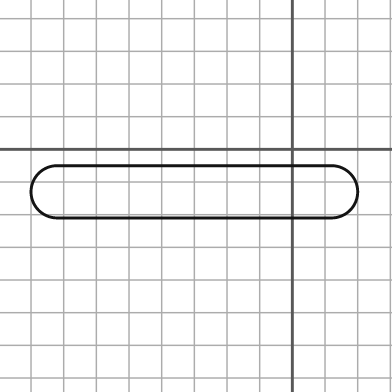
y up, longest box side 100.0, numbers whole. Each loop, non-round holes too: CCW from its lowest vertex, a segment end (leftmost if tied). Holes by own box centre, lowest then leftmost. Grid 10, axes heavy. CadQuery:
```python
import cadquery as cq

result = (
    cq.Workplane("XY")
    .moveTo(-72.0, -21.0)
    .lineTo(12.0, -21.0)
    .threePointArc((20.0, -13.0), (12.0, -5.0))
    .lineTo(-72.0, -5.0)
    .threePointArc((-80.0, -13.0), (-72.0, -21.0))
    .close()
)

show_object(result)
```